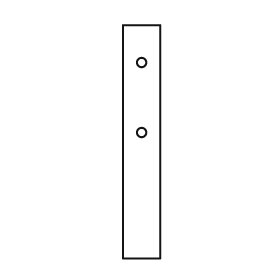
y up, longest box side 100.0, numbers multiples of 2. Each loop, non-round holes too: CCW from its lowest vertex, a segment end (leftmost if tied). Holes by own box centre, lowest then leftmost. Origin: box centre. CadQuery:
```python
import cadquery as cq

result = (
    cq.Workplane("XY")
    .moveTo(-8.0, -50.0)
    .lineTo(8.0, -50.0)
    .lineTo(8.0, 50.0)
    .lineTo(-8.0, 50.0)
    .close()
    .moveTo(0.0, 4.0)
    .circle(2.0)
    .moveTo(0.0, 34.0)
    .circle(2.0)
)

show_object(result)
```